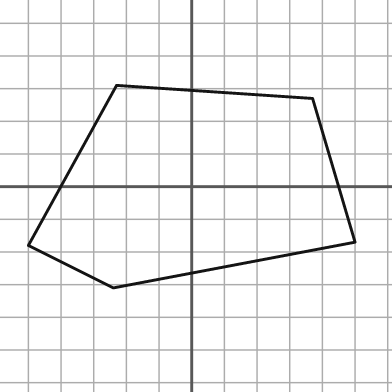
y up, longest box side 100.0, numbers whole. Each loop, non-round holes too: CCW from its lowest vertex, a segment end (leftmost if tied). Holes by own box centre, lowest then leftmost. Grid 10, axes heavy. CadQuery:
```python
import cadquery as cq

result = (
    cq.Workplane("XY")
    .moveTo(-24.0, -31.0)
    .lineTo(50.0, -17.0)
    .lineTo(37.0, 27.0)
    .lineTo(-23.0, 31.0)
    .lineTo(-50.0, -18.0)
    .close()
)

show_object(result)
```